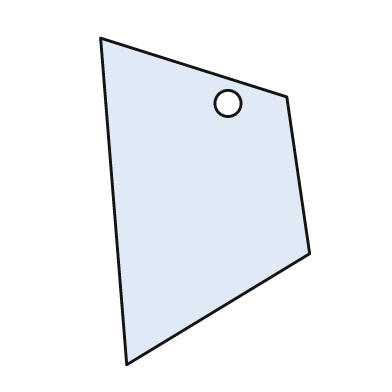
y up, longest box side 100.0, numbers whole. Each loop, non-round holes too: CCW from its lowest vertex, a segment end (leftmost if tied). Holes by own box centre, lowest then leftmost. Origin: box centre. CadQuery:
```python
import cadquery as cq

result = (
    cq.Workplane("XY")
    .moveTo(-24.0, -50.0)
    .lineTo(32.0, -16.0)
    .lineTo(25.0, 32.0)
    .lineTo(-32.0, 50.0)
    .close()
    .moveTo(7.0, 30.0)
    .circle(4.0)
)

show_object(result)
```